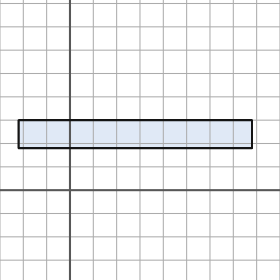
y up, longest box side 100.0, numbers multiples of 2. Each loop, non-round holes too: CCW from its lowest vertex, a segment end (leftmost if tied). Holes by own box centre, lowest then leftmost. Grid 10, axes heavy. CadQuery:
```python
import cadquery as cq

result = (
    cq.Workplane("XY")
    .moveTo(-22.0, 18.0)
    .lineTo(78.0, 18.0)
    .lineTo(78.0, 30.0)
    .lineTo(-22.0, 30.0)
    .close()
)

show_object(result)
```